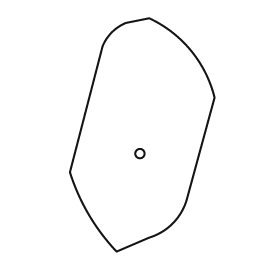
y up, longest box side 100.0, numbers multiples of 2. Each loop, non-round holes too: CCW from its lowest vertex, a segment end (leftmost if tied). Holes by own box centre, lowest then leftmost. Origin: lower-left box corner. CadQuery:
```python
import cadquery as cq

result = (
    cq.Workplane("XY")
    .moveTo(20.0, 0.0)
    .lineTo(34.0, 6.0)
    .threePointArc((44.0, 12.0), (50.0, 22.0))
    .lineTo(62.0, 66.0)
    .threePointArc((52.0, 86.0), (34.0, 100.0))
    .lineTo(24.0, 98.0)
    .threePointArc((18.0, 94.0), (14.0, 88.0))
    .lineTo(0.0, 34.0)
    .threePointArc((8.0, 16.0), (20.0, 0.0))
    .close()
    .moveTo(30.0, 42.0)
    .circle(2.0)
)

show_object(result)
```